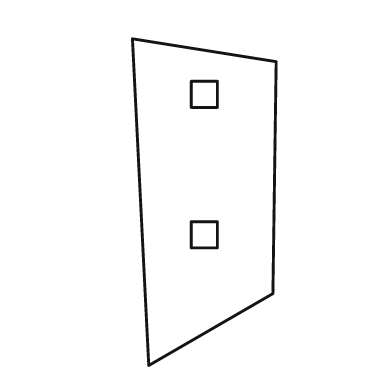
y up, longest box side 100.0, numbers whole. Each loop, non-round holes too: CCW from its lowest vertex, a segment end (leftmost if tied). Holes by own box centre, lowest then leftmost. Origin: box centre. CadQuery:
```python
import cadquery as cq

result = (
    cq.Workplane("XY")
    .moveTo(-17.0, -50.0)
    .lineTo(21.0, -28.0)
    .lineTo(22.0, 43.0)
    .lineTo(-22.0, 50.0)
    .close()
    .moveTo(-4.0, -14.0)
    .lineTo(4.0, -14.0)
    .lineTo(4.0, -6.0)
    .lineTo(-4.0, -6.0)
    .close()
    .moveTo(-4.0, 29.0)
    .lineTo(4.0, 29.0)
    .lineTo(4.0, 37.0)
    .lineTo(-4.0, 37.0)
    .close()
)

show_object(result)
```